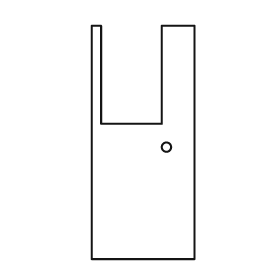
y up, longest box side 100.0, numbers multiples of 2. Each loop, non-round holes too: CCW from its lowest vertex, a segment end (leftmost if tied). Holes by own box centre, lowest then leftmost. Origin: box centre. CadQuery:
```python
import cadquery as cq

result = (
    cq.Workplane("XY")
    .moveTo(-22.0, -50.0)
    .lineTo(22.0, -50.0)
    .lineTo(22.0, 50.0)
    .lineTo(8.0, 50.0)
    .lineTo(8.0, 8.0)
    .lineTo(-18.0, 8.0)
    .lineTo(-18.0, 50.0)
    .lineTo(-22.0, 50.0)
    .close()
    .moveTo(10.0, -2.0)
    .circle(2.0)
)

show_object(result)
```